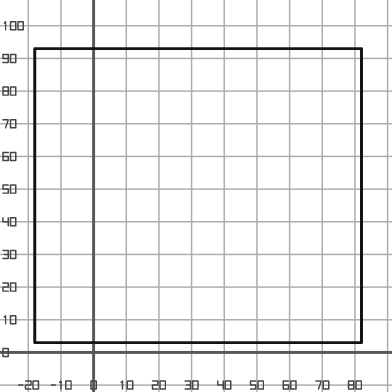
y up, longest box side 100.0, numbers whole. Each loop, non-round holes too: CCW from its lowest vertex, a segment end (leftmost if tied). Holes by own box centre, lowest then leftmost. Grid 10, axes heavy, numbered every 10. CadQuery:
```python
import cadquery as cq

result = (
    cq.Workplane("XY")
    .moveTo(-18.0, 3.0)
    .lineTo(82.0, 3.0)
    .lineTo(82.0, 93.0)
    .lineTo(-18.0, 93.0)
    .close()
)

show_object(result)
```